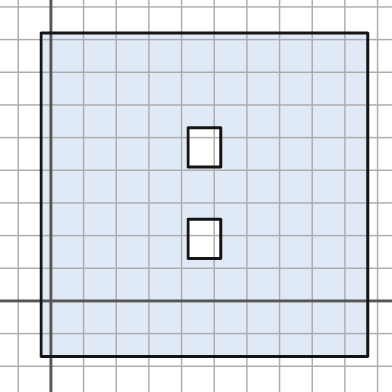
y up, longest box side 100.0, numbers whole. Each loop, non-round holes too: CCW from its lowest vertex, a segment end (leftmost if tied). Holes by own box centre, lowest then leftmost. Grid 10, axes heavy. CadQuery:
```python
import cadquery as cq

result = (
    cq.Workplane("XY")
    .moveTo(-3.0, -17.0)
    .lineTo(97.0, -17.0)
    .lineTo(97.0, 82.0)
    .lineTo(-3.0, 82.0)
    .close()
    .moveTo(42.0, 13.0)
    .lineTo(52.0, 13.0)
    .lineTo(52.0, 25.0)
    .lineTo(42.0, 25.0)
    .close()
    .moveTo(42.0, 41.0)
    .lineTo(52.0, 41.0)
    .lineTo(52.0, 53.0)
    .lineTo(42.0, 53.0)
    .close()
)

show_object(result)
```